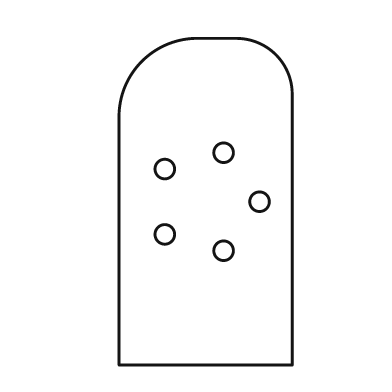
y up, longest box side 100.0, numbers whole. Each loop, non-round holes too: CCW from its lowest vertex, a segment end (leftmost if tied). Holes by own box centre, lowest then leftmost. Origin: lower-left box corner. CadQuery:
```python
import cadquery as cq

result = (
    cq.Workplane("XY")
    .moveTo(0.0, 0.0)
    .lineTo(53.0, 0.0)
    .lineTo(53.0, 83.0)
    .threePointArc((48.0, 95.0), (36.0, 100.0))
    .lineTo(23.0, 100.0)
    .threePointArc((7.0, 93.0), (0.0, 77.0))
    .close()
    .moveTo(32.0, 35.0)
    .circle(3.0)
    .moveTo(14.0, 40.0)
    .circle(3.0)
    .moveTo(43.0, 50.0)
    .circle(3.0)
    .moveTo(14.0, 60.0)
    .circle(3.0)
    .moveTo(32.0, 65.0)
    .circle(3.0)
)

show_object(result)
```